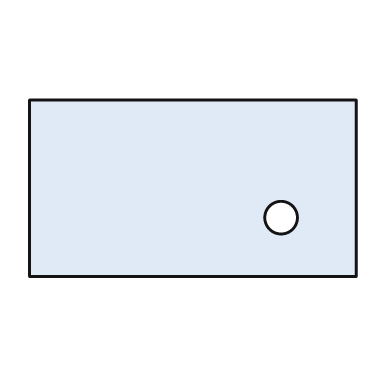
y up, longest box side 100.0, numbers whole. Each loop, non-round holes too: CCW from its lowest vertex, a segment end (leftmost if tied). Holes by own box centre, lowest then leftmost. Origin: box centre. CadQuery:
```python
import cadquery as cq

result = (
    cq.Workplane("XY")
    .moveTo(-50.0, -27.0)
    .lineTo(50.0, -27.0)
    .lineTo(50.0, 27.0)
    .lineTo(-50.0, 27.0)
    .close()
    .moveTo(27.0, -9.0)
    .circle(5.0)
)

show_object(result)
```